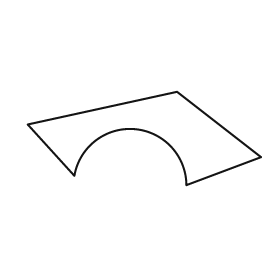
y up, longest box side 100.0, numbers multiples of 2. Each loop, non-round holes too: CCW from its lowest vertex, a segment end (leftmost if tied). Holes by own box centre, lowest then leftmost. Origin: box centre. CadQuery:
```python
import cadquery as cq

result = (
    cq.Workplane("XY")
    .moveTo(18.0, -20.0)
    .lineTo(50.0, -8.0)
    .lineTo(14.0, 20.0)
    .lineTo(-50.0, 6.0)
    .lineTo(-30.0, -16.0)
    .threePointArc((-4.0, 4.0), (18.0, -20.0))
    .close()
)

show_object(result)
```